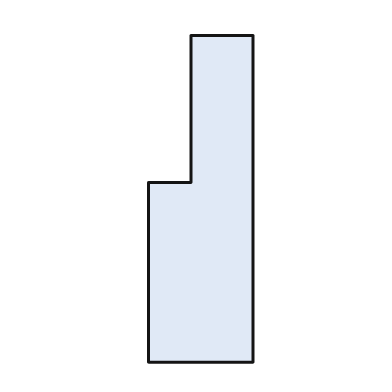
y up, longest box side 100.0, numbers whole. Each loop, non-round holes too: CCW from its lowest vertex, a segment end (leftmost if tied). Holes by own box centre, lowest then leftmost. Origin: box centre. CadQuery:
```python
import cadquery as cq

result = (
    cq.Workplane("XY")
    .moveTo(-16.0, -50.0)
    .lineTo(16.0, -50.0)
    .lineTo(16.0, 50.0)
    .lineTo(-3.0, 50.0)
    .lineTo(-3.0, 5.0)
    .lineTo(-16.0, 5.0)
    .close()
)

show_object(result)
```